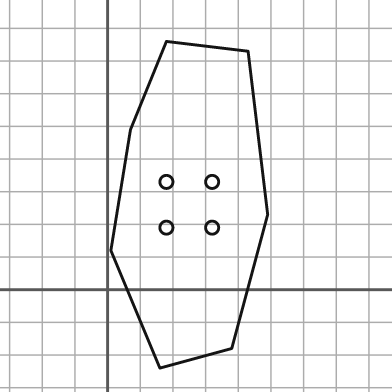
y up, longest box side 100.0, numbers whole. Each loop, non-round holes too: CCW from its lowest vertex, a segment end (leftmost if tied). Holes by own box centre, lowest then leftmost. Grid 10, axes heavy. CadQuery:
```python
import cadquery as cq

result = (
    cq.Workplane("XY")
    .moveTo(16.0, -24.0)
    .lineTo(38.0, -18.0)
    .lineTo(49.0, 23.0)
    .lineTo(43.0, 73.0)
    .lineTo(18.0, 76.0)
    .lineTo(7.0, 49.0)
    .lineTo(1.0, 12.0)
    .close()
    .moveTo(18.0, 19.0)
    .circle(2.0)
    .moveTo(32.0, 19.0)
    .circle(2.0)
    .moveTo(18.0, 33.0)
    .circle(2.0)
    .moveTo(32.0, 33.0)
    .circle(2.0)
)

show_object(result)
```